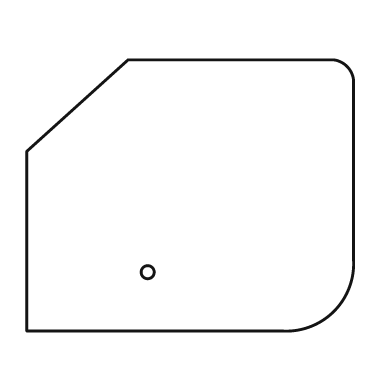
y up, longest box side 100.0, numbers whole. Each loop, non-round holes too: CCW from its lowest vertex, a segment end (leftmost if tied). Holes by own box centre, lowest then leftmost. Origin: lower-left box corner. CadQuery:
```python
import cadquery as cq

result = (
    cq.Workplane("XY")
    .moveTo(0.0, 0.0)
    .lineTo(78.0, 0.0)
    .threePointArc((94.0, 6.0), (100.0, 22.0))
    .lineTo(100.0, 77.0)
    .threePointArc((98.0, 81.0), (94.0, 83.0))
    .lineTo(31.0, 83.0)
    .lineTo(0.0, 55.0)
    .close()
    .moveTo(37.0, 18.0)
    .circle(2.0)
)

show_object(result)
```